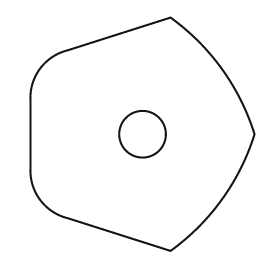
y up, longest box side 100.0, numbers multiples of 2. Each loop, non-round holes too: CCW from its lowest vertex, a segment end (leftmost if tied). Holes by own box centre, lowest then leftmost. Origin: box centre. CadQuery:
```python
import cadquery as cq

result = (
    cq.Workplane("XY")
    .moveTo(12.0, -50.0)
    .threePointArc((34.0, -28.0), (48.0, 0.0))
    .threePointArc((34.0, 28.0), (12.0, 50.0))
    .lineTo(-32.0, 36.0)
    .threePointArc((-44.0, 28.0), (-48.0, 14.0))
    .lineTo(-48.0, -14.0)
    .threePointArc((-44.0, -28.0), (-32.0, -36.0))
    .close()
    .moveTo(0.0, 0.0)
    .circle(10.0)
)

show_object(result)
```